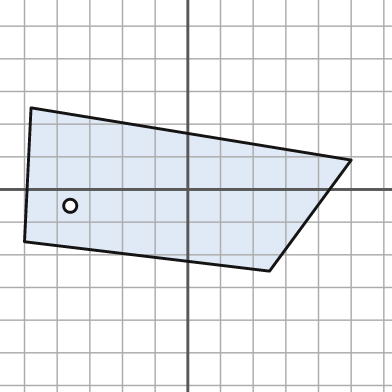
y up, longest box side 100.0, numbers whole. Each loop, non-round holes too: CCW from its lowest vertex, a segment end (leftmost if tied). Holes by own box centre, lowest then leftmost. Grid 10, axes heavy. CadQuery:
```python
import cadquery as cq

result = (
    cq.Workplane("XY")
    .moveTo(25.0, -25.0)
    .lineTo(50.0, 9.0)
    .lineTo(-48.0, 25.0)
    .lineTo(-50.0, -16.0)
    .close()
    .moveTo(-36.0, -5.0)
    .circle(2.0)
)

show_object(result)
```